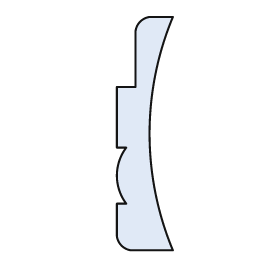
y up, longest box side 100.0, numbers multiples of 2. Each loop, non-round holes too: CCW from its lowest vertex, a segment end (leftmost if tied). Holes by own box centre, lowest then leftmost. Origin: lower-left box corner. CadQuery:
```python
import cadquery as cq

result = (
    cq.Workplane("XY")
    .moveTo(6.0, 0.0)
    .lineTo(24.0, 0.0)
    .threePointArc((14.0, 50.0), (24.0, 100.0))
    .lineTo(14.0, 100.0)
    .threePointArc((10.0, 98.0), (8.0, 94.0))
    .lineTo(8.0, 70.0)
    .lineTo(0.0, 70.0)
    .lineTo(0.0, 44.0)
    .lineTo(4.0, 44.0)
    .threePointArc((0.0, 32.0), (4.0, 20.0))
    .lineTo(0.0, 20.0)
    .lineTo(0.0, 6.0)
    .threePointArc((2.0, 2.0), (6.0, 0.0))
    .close()
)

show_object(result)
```